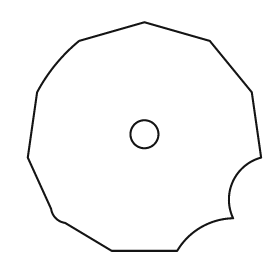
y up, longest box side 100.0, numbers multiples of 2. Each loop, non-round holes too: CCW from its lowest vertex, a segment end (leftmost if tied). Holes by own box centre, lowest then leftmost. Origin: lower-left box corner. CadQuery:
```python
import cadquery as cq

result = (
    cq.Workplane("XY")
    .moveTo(36.0, 0.0)
    .lineTo(64.0, 0.0)
    .threePointArc((74.0, 10.0), (88.0, 14.0))
    .threePointArc((88.0, 30.0), (100.0, 40.0))
    .lineTo(96.0, 68.0)
    .lineTo(78.0, 90.0)
    .lineTo(50.0, 98.0)
    .lineTo(22.0, 90.0)
    .threePointArc((12.0, 80.0), (4.0, 68.0))
    .lineTo(0.0, 40.0)
    .lineTo(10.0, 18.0)
    .threePointArc((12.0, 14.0), (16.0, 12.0))
    .close()
    .moveTo(50.0, 50.0)
    .circle(6.0)
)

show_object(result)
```